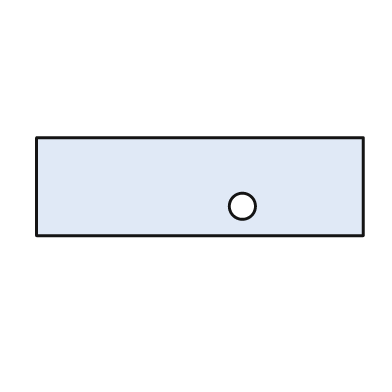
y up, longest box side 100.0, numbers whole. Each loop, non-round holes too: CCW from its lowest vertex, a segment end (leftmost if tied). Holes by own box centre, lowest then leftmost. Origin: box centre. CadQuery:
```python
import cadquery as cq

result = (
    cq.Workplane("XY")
    .moveTo(-50.0, -15.0)
    .lineTo(50.0, -15.0)
    .lineTo(50.0, 15.0)
    .lineTo(-50.0, 15.0)
    .close()
    .moveTo(13.0, -6.0)
    .circle(4.0)
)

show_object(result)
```